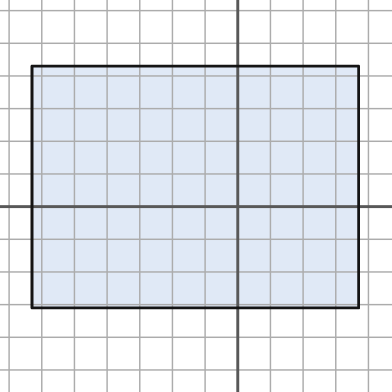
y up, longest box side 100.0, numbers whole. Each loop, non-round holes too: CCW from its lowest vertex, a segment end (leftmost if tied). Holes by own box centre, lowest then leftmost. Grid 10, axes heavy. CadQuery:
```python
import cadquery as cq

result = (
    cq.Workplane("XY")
    .moveTo(-63.0, -31.0)
    .lineTo(37.0, -31.0)
    .lineTo(37.0, 43.0)
    .lineTo(-63.0, 43.0)
    .close()
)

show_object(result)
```